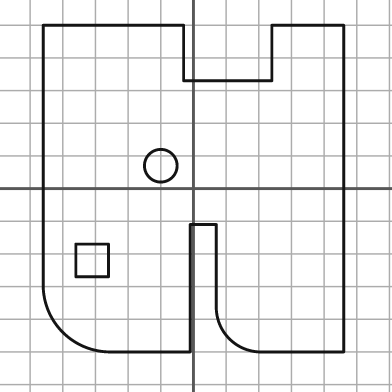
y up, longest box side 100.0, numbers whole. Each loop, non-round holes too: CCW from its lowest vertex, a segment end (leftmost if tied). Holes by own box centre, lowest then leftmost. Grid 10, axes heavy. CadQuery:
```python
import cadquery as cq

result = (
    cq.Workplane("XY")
    .moveTo(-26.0, -50.0)
    .lineTo(-1.0, -50.0)
    .lineTo(-1.0, -11.0)
    .lineTo(7.0, -11.0)
    .lineTo(7.0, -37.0)
    .threePointArc((11.0, -46.0), (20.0, -50.0))
    .lineTo(46.0, -50.0)
    .lineTo(46.0, 50.0)
    .lineTo(24.0, 50.0)
    .lineTo(24.0, 33.0)
    .lineTo(-3.0, 33.0)
    .lineTo(-3.0, 50.0)
    .lineTo(-46.0, 50.0)
    .lineTo(-46.0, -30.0)
    .threePointArc((-40.0, -44.0), (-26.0, -50.0))
    .close()
    .moveTo(-36.0, -27.0)
    .lineTo(-26.0, -27.0)
    .lineTo(-26.0, -17.0)
    .lineTo(-36.0, -17.0)
    .close()
    .moveTo(-10.0, 7.0)
    .circle(5.0)
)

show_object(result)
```